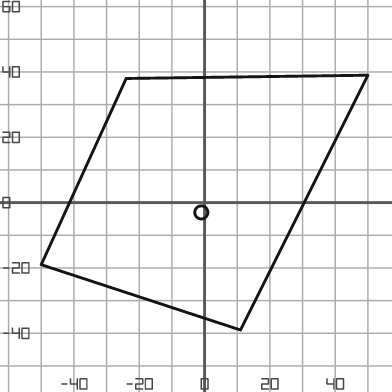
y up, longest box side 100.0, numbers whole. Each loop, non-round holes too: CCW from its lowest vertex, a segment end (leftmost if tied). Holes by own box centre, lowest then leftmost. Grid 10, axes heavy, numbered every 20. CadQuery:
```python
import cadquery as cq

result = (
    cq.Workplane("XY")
    .moveTo(11.0, -39.0)
    .lineTo(50.0, 39.0)
    .lineTo(-24.0, 38.0)
    .lineTo(-50.0, -19.0)
    .close()
    .moveTo(-1.0, -3.0)
    .circle(2.0)
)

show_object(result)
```